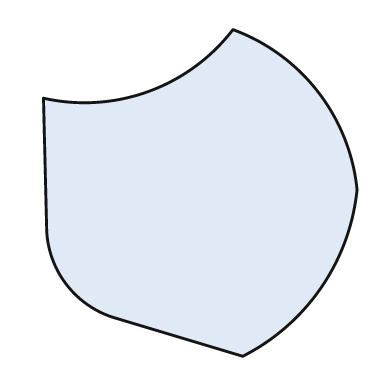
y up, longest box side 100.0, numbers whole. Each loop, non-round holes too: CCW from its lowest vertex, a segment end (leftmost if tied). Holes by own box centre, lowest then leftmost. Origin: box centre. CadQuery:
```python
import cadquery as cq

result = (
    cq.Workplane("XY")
    .moveTo(13.0, -50.0)
    .threePointArc((37.0, -29.0), (48.0, 1.0))
    .threePointArc((36.0, 31.0), (10.0, 50.0))
    .threePointArc((-16.0, 31.0), (-48.0, 29.0))
    .lineTo(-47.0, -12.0)
    .threePointArc((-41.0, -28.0), (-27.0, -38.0))
    .close()
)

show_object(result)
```